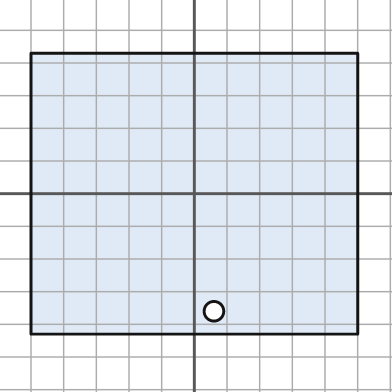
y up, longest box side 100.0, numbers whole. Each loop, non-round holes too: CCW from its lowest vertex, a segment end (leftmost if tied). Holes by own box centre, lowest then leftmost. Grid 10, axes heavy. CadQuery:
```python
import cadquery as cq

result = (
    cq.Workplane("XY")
    .moveTo(-50.0, -43.0)
    .lineTo(50.0, -43.0)
    .lineTo(50.0, 43.0)
    .lineTo(-50.0, 43.0)
    .close()
    .moveTo(6.0, -36.0)
    .circle(3.0)
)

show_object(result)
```